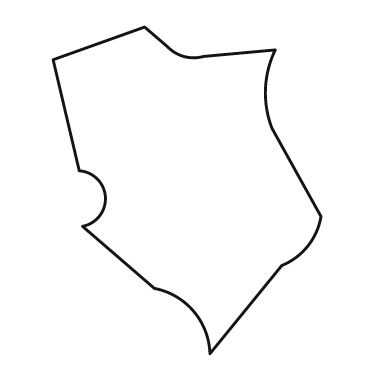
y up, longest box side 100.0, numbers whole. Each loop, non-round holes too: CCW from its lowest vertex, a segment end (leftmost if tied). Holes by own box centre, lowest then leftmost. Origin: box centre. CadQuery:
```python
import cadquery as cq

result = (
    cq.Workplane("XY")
    .moveTo(7.0, -50.0)
    .lineTo(29.0, -23.0)
    .threePointArc((37.0, -17.0), (41.0, -8.0))
    .lineTo(26.0, 19.0)
    .threePointArc((24.0, 31.0), (27.0, 43.0))
    .lineTo(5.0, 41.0)
    .threePointArc((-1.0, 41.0), (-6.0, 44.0))
    .lineTo(-13.0, 50.0)
    .lineTo(-41.0, 40.0)
    .lineTo(-33.0, 6.0)
    .threePointArc((-25.0, -2.0), (-32.0, -11.0))
    .lineTo(-10.0, -30.0)
    .threePointArc((2.0, -37.0), (7.0, -50.0))
    .close()
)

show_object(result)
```